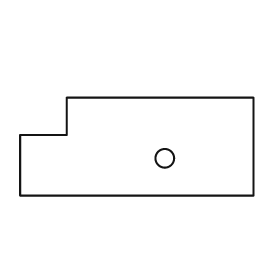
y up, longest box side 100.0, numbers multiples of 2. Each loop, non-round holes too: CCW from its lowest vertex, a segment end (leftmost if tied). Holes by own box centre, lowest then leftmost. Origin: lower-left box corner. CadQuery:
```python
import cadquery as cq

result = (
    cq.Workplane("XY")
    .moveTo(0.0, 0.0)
    .lineTo(100.0, 0.0)
    .lineTo(100.0, 42.0)
    .lineTo(20.0, 42.0)
    .lineTo(20.0, 26.0)
    .lineTo(0.0, 26.0)
    .close()
    .moveTo(62.0, 16.0)
    .circle(4.0)
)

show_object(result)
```